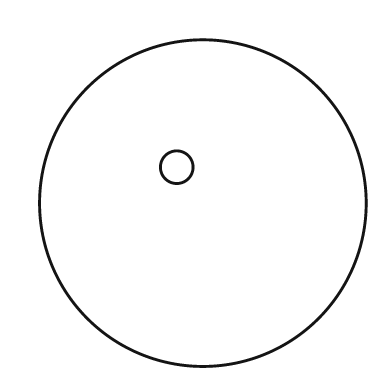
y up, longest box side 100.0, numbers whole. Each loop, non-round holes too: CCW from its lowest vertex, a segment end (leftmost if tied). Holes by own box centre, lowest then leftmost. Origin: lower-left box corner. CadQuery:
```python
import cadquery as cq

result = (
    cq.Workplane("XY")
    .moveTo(50.0, 50.0)
    .circle(50.0)
    .moveTo(42.0, 61.0)
    .circle(5.0)
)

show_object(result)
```